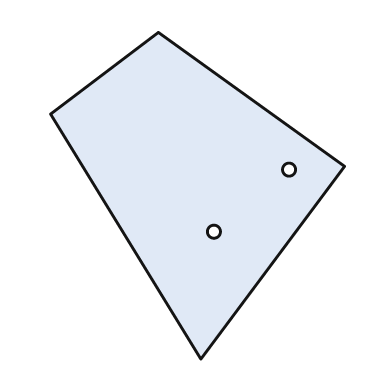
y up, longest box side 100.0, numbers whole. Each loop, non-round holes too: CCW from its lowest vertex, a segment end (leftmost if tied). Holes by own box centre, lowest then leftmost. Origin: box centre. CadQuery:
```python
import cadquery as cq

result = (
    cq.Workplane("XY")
    .moveTo(1.0, -50.0)
    .lineTo(45.0, 9.0)
    .lineTo(-12.0, 50.0)
    .lineTo(-45.0, 25.0)
    .close()
    .moveTo(5.0, -11.0)
    .circle(2.0)
    .moveTo(28.0, 8.0)
    .circle(2.0)
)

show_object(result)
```